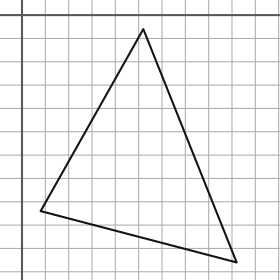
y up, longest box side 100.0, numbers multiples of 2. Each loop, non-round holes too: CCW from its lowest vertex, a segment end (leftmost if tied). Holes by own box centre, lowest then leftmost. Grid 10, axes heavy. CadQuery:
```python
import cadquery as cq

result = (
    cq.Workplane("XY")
    .moveTo(92.0, -106.0)
    .lineTo(52.0, -6.0)
    .lineTo(8.0, -84.0)
    .close()
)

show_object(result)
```